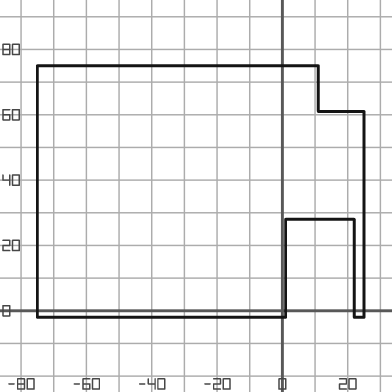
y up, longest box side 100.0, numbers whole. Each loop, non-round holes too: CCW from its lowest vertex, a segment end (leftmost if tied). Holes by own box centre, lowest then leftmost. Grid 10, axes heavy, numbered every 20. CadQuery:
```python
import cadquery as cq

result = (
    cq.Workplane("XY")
    .moveTo(-75.0, -2.0)
    .lineTo(1.0, -2.0)
    .lineTo(1.0, 28.0)
    .lineTo(22.0, 28.0)
    .lineTo(22.0, -2.0)
    .lineTo(25.0, -2.0)
    .lineTo(25.0, 61.0)
    .lineTo(11.0, 61.0)
    .lineTo(11.0, 75.0)
    .lineTo(-75.0, 75.0)
    .close()
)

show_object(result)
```